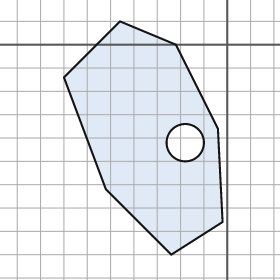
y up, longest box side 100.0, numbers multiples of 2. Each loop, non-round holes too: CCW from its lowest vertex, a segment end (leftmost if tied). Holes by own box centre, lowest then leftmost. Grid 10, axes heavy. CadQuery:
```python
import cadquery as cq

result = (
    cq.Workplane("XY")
    .moveTo(-24.0, -90.0)
    .lineTo(-2.0, -76.0)
    .lineTo(-4.0, -36.0)
    .lineTo(-22.0, 0.0)
    .lineTo(-46.0, 10.0)
    .lineTo(-70.0, -14.0)
    .lineTo(-52.0, -62.0)
    .close()
    .moveTo(-18.0, -42.0)
    .circle(8.0)
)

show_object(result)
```